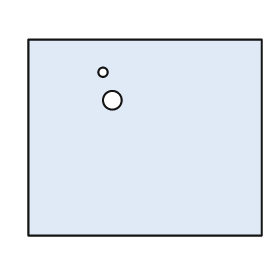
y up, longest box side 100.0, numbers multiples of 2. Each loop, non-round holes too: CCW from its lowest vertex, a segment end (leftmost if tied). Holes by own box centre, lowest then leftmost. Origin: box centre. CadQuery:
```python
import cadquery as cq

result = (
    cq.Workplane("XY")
    .moveTo(-50.0, -42.0)
    .lineTo(50.0, -42.0)
    .lineTo(50.0, 42.0)
    .lineTo(-50.0, 42.0)
    .close()
    .moveTo(-14.0, 16.0)
    .circle(4.0)
    .moveTo(-18.0, 28.0)
    .circle(2.0)
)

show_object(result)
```